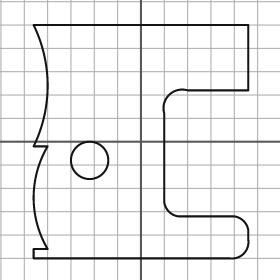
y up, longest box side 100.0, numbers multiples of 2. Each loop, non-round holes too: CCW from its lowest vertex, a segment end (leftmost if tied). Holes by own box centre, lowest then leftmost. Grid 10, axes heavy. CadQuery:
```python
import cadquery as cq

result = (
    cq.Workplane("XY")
    .moveTo(-46.0, -50.0)
    .lineTo(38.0, -50.0)
    .threePointArc((44.0, -48.0), (46.0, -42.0))
    .lineTo(46.0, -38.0)
    .threePointArc((44.0, -34.0), (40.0, -32.0))
    .lineTo(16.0, -32.0)
    .threePointArc((12.0, -30.0), (10.0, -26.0))
    .lineTo(10.0, 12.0)
    .threePointArc((12.0, 20.0), (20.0, 22.0))
    .lineTo(46.0, 22.0)
    .lineTo(46.0, 50.0)
    .lineTo(-46.0, 50.0)
    .threePointArc((-40.0, 24.0), (-46.0, -2.0))
    .lineTo(-40.0, -2.0)
    .threePointArc((-46.0, -24.0), (-40.0, -46.0))
    .lineTo(-46.0, -46.0)
    .close()
    .moveTo(-22.0, -8.0)
    .circle(8.0)
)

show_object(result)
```